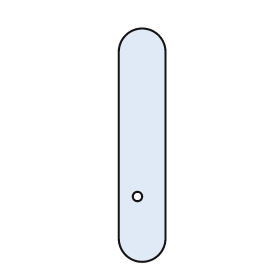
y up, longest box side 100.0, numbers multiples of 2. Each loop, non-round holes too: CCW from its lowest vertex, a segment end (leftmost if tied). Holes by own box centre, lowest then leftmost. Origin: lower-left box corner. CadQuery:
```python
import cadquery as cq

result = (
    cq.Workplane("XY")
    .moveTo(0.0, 10.0)
    .threePointArc((10.0, 0.0), (20.0, 10.0))
    .lineTo(20.0, 90.0)
    .threePointArc((10.0, 100.0), (0.0, 90.0))
    .close()
    .moveTo(8.0, 28.0)
    .circle(2.0)
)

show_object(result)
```